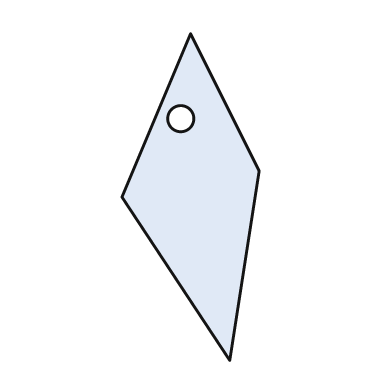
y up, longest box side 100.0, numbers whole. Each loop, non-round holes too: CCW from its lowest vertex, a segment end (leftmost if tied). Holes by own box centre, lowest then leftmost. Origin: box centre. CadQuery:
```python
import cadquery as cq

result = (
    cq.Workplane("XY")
    .moveTo(12.0, -50.0)
    .lineTo(21.0, 8.0)
    .lineTo(0.0, 50.0)
    .lineTo(-21.0, 0.0)
    .close()
    .moveTo(-3.0, 24.0)
    .circle(4.0)
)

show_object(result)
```